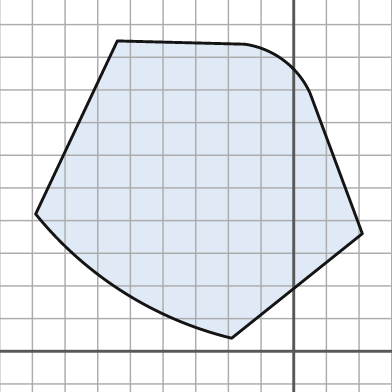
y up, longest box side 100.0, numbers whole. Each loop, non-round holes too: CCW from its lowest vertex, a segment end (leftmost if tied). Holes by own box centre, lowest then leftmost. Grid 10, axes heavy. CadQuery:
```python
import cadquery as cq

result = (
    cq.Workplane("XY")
    .moveTo(-19.0, 4.0)
    .lineTo(21.0, 36.0)
    .lineTo(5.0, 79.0)
    .threePointArc((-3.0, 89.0), (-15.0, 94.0))
    .lineTo(-54.0, 95.0)
    .lineTo(-79.0, 42.0)
    .threePointArc((-52.0, 18.0), (-19.0, 4.0))
    .close()
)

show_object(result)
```